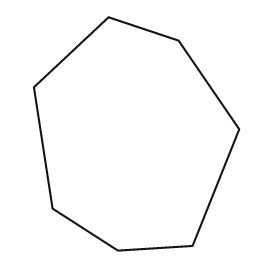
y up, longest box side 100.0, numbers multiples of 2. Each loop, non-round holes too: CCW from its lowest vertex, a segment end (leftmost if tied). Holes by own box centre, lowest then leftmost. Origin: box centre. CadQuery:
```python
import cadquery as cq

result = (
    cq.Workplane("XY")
    .moveTo(-8.0, -50.0)
    .lineTo(24.0, -48.0)
    .lineTo(44.0, 2.0)
    .lineTo(18.0, 40.0)
    .lineTo(-12.0, 50.0)
    .lineTo(-44.0, 20.0)
    .lineTo(-36.0, -32.0)
    .close()
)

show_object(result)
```